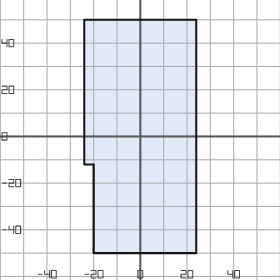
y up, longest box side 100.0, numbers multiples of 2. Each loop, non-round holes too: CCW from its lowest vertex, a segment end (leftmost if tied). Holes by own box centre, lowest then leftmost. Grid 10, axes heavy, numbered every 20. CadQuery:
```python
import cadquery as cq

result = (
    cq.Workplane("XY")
    .moveTo(-20.0, -50.0)
    .lineTo(24.0, -50.0)
    .lineTo(24.0, 50.0)
    .lineTo(-24.0, 50.0)
    .lineTo(-24.0, -12.0)
    .lineTo(-20.0, -12.0)
    .close()
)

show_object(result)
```